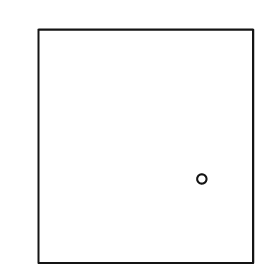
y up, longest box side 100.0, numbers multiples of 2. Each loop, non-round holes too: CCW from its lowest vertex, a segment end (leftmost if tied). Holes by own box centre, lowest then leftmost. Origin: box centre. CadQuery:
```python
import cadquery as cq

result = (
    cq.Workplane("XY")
    .moveTo(-46.0, -50.0)
    .lineTo(46.0, -50.0)
    .lineTo(46.0, 50.0)
    .lineTo(-46.0, 50.0)
    .close()
    .moveTo(24.0, -14.0)
    .circle(2.0)
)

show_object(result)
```